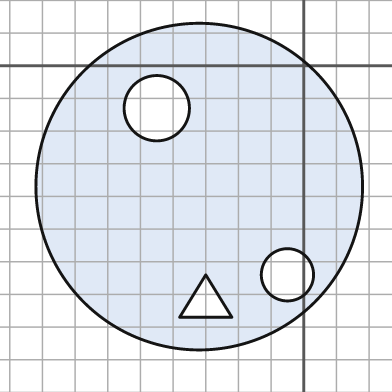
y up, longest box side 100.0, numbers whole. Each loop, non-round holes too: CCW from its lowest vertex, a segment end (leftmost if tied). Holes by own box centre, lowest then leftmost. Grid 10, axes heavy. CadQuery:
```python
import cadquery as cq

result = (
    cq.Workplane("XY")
    .moveTo(-32.0, -37.0)
    .circle(50.0)
    .moveTo(-38.0, -77.0)
    .lineTo(-22.0, -77.0)
    .lineTo(-30.0, -64.0)
    .close()
    .moveTo(-5.0, -64.0)
    .circle(8.0)
    .moveTo(-45.0, -13.0)
    .circle(10.0)
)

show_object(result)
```